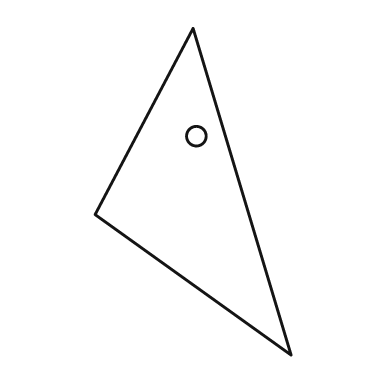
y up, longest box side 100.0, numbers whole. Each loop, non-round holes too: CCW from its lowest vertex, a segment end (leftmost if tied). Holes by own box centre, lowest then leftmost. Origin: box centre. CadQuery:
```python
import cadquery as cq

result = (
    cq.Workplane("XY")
    .moveTo(30.0, -50.0)
    .lineTo(0.0, 50.0)
    .lineTo(-30.0, -7.0)
    .close()
    .moveTo(1.0, 17.0)
    .circle(3.0)
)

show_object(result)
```